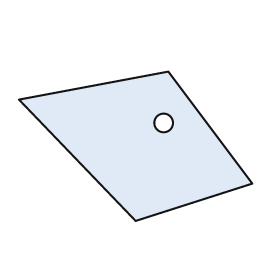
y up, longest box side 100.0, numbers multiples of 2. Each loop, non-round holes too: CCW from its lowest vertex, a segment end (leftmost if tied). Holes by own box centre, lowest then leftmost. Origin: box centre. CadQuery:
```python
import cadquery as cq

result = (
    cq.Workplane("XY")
    .moveTo(0.0, -32.0)
    .lineTo(50.0, -16.0)
    .lineTo(14.0, 32.0)
    .lineTo(-50.0, 20.0)
    .close()
    .moveTo(12.0, 10.0)
    .circle(4.0)
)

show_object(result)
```